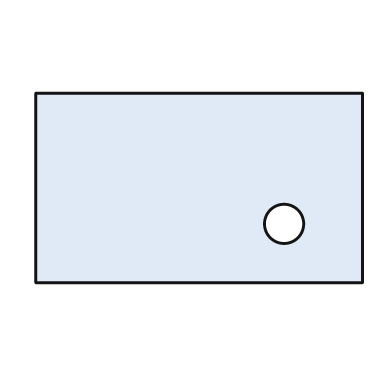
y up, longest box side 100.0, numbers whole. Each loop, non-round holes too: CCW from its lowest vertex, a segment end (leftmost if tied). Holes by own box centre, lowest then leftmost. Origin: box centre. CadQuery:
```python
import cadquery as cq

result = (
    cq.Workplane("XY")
    .moveTo(-50.0, -29.0)
    .lineTo(50.0, -29.0)
    .lineTo(50.0, 29.0)
    .lineTo(-50.0, 29.0)
    .close()
    .moveTo(26.0, -11.0)
    .circle(6.0)
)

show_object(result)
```